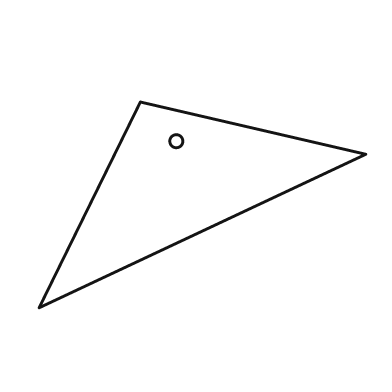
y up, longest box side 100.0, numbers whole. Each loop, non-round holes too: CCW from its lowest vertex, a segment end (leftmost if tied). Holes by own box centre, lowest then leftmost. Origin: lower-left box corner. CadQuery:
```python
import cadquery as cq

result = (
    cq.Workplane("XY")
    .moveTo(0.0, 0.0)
    .lineTo(100.0, 47.0)
    .lineTo(31.0, 63.0)
    .close()
    .moveTo(42.0, 51.0)
    .circle(2.0)
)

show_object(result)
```